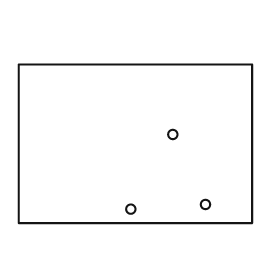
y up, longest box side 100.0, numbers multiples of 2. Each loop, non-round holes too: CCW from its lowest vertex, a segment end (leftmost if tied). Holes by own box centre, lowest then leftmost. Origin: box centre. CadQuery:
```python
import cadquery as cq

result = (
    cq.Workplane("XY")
    .moveTo(-50.0, -34.0)
    .lineTo(50.0, -34.0)
    .lineTo(50.0, 34.0)
    .lineTo(-50.0, 34.0)
    .close()
    .moveTo(-2.0, -28.0)
    .circle(2.0)
    .moveTo(30.0, -26.0)
    .circle(2.0)
    .moveTo(16.0, 4.0)
    .circle(2.0)
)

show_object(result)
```